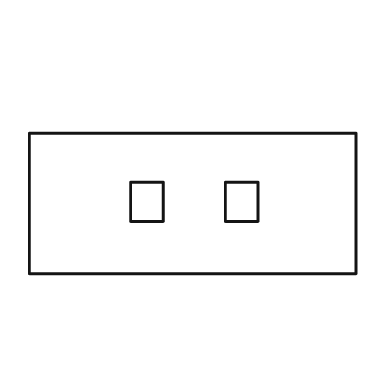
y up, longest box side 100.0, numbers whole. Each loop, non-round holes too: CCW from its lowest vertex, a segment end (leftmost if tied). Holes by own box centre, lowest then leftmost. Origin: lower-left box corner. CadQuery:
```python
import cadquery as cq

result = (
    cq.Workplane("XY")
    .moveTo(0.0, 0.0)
    .lineTo(100.0, 0.0)
    .lineTo(100.0, 43.0)
    .lineTo(0.0, 43.0)
    .close()
    .moveTo(31.0, 16.0)
    .lineTo(41.0, 16.0)
    .lineTo(41.0, 28.0)
    .lineTo(31.0, 28.0)
    .close()
    .moveTo(60.0, 16.0)
    .lineTo(70.0, 16.0)
    .lineTo(70.0, 28.0)
    .lineTo(60.0, 28.0)
    .close()
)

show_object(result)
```